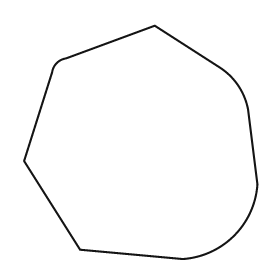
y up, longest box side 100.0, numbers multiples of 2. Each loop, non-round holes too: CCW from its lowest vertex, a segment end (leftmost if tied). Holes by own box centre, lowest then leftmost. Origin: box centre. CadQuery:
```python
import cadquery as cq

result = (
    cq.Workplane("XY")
    .moveTo(18.0, -50.0)
    .threePointArc((40.0, -40.0), (50.0, -18.0))
    .lineTo(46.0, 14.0)
    .threePointArc((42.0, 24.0), (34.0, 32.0))
    .lineTo(6.0, 50.0)
    .lineTo(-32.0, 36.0)
    .threePointArc((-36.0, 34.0), (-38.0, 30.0))
    .lineTo(-50.0, -8.0)
    .lineTo(-26.0, -46.0)
    .close()
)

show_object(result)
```